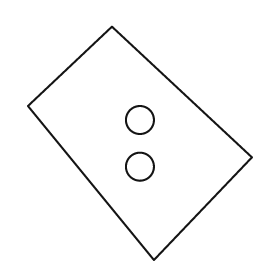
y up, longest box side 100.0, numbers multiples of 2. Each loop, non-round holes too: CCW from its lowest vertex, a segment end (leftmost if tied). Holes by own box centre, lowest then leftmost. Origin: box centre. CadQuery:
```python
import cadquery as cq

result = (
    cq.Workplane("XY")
    .moveTo(6.0, -50.0)
    .lineTo(48.0, -6.0)
    .lineTo(-12.0, 50.0)
    .lineTo(-48.0, 16.0)
    .close()
    .moveTo(0.0, -10.0)
    .circle(6.0)
    .moveTo(0.0, 10.0)
    .circle(6.0)
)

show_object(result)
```